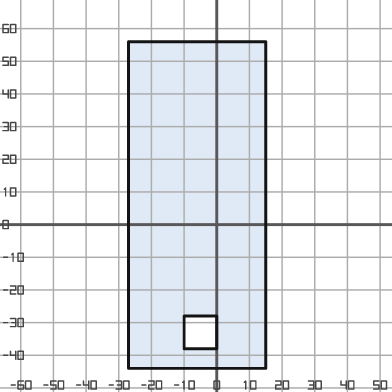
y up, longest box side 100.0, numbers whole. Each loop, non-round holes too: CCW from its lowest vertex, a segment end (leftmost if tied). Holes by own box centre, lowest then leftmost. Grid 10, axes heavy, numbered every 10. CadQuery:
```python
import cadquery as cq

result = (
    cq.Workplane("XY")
    .moveTo(-27.0, -44.0)
    .lineTo(15.0, -44.0)
    .lineTo(15.0, 56.0)
    .lineTo(-27.0, 56.0)
    .close()
    .moveTo(-10.0, -38.0)
    .lineTo(0.0, -38.0)
    .lineTo(0.0, -28.0)
    .lineTo(-10.0, -28.0)
    .close()
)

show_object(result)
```